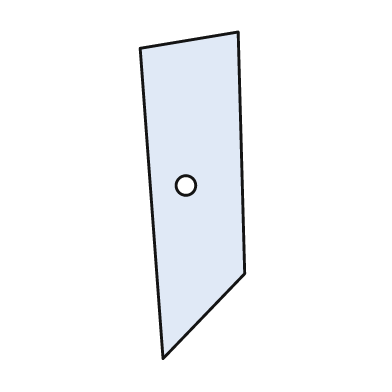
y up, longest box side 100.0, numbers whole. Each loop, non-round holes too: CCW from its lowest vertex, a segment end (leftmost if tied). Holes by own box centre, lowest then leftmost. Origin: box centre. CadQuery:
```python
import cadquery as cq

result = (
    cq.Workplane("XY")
    .moveTo(-9.0, -50.0)
    .lineTo(16.0, -24.0)
    .lineTo(14.0, 50.0)
    .lineTo(-16.0, 45.0)
    .close()
    .moveTo(-2.0, 3.0)
    .circle(3.0)
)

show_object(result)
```